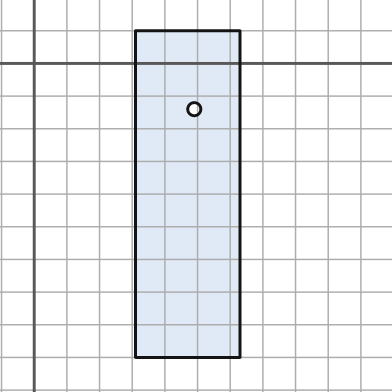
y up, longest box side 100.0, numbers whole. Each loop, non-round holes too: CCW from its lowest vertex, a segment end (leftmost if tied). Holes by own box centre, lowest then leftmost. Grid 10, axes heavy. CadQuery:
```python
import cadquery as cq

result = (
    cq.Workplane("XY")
    .moveTo(31.0, -90.0)
    .lineTo(63.0, -90.0)
    .lineTo(63.0, 10.0)
    .lineTo(31.0, 10.0)
    .close()
    .moveTo(49.0, -14.0)
    .circle(2.0)
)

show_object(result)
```